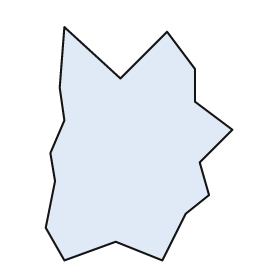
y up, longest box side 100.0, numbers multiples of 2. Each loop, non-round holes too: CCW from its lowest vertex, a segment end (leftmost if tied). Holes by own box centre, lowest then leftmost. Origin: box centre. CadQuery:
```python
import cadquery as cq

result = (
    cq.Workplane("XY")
    .moveTo(-32.0, -50.0)
    .lineTo(-10.0, -42.0)
    .lineTo(10.0, -50.0)
    .lineTo(20.0, -30.0)
    .lineTo(30.0, -22.0)
    .lineTo(26.0, -8.0)
    .lineTo(40.0, 6.0)
    .lineTo(24.0, 18.0)
    .lineTo(24.0, 32.0)
    .lineTo(12.0, 48.0)
    .lineTo(-8.0, 28.0)
    .lineTo(-32.0, 50.0)
    .lineTo(-34.0, 24.0)
    .lineTo(-32.0, 10.0)
    .lineTo(-38.0, -4.0)
    .lineTo(-36.0, -16.0)
    .lineTo(-40.0, -36.0)
    .close()
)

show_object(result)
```